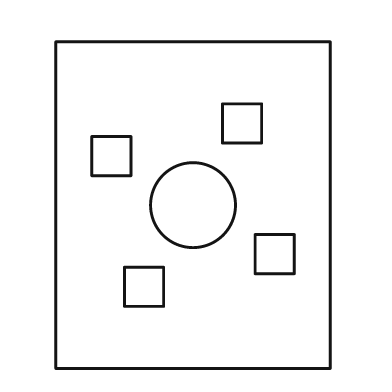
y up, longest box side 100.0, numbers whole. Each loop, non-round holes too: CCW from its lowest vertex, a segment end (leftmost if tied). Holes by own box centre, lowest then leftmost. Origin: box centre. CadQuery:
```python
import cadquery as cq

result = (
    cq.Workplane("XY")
    .moveTo(-42.0, -50.0)
    .lineTo(42.0, -50.0)
    .lineTo(42.0, 50.0)
    .lineTo(-42.0, 50.0)
    .close()
    .moveTo(-21.0, -31.0)
    .lineTo(-9.0, -31.0)
    .lineTo(-9.0, -19.0)
    .lineTo(-21.0, -19.0)
    .close()
    .moveTo(19.0, -21.0)
    .lineTo(31.0, -21.0)
    .lineTo(31.0, -9.0)
    .lineTo(19.0, -9.0)
    .close()
    .moveTo(0.0, 0.0)
    .circle(13.0)
    .moveTo(-31.0, 9.0)
    .lineTo(-19.0, 9.0)
    .lineTo(-19.0, 21.0)
    .lineTo(-31.0, 21.0)
    .close()
    .moveTo(9.0, 19.0)
    .lineTo(21.0, 19.0)
    .lineTo(21.0, 31.0)
    .lineTo(9.0, 31.0)
    .close()
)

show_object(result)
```